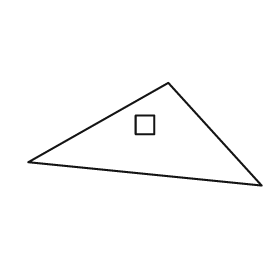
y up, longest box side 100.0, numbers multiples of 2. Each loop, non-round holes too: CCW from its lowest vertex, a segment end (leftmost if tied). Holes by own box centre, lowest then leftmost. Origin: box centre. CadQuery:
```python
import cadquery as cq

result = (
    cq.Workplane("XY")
    .moveTo(50.0, -22.0)
    .lineTo(10.0, 22.0)
    .lineTo(-50.0, -12.0)
    .close()
    .moveTo(-4.0, 0.0)
    .lineTo(4.0, 0.0)
    .lineTo(4.0, 8.0)
    .lineTo(-4.0, 8.0)
    .close()
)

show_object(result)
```